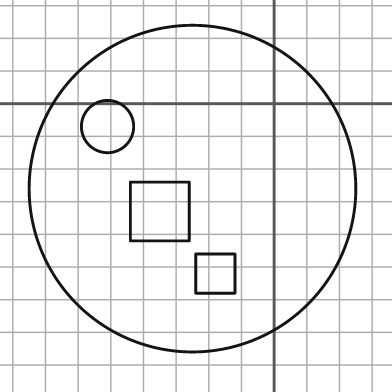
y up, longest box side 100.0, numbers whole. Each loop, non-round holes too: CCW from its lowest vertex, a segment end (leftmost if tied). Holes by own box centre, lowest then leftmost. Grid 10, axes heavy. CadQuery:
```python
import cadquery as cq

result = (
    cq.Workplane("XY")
    .moveTo(-25.0, -26.0)
    .circle(50.0)
    .moveTo(-24.0, -58.0)
    .lineTo(-12.0, -58.0)
    .lineTo(-12.0, -46.0)
    .lineTo(-24.0, -46.0)
    .close()
    .moveTo(-44.0, -42.0)
    .lineTo(-26.0, -42.0)
    .lineTo(-26.0, -24.0)
    .lineTo(-44.0, -24.0)
    .close()
    .moveTo(-51.0, -7.0)
    .circle(8.0)
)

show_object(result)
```